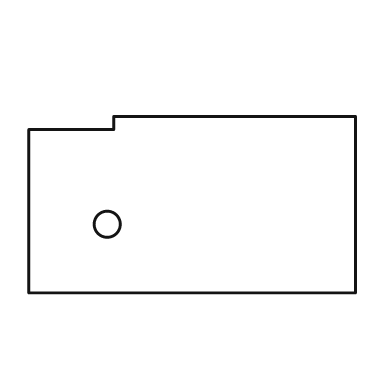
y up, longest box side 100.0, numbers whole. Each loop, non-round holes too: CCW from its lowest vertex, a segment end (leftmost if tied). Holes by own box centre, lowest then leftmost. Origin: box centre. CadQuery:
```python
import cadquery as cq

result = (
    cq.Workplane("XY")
    .moveTo(-50.0, -27.0)
    .lineTo(50.0, -27.0)
    .lineTo(50.0, 27.0)
    .lineTo(-24.0, 27.0)
    .lineTo(-24.0, 23.0)
    .lineTo(-50.0, 23.0)
    .close()
    .moveTo(-26.0, -6.0)
    .circle(4.0)
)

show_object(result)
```